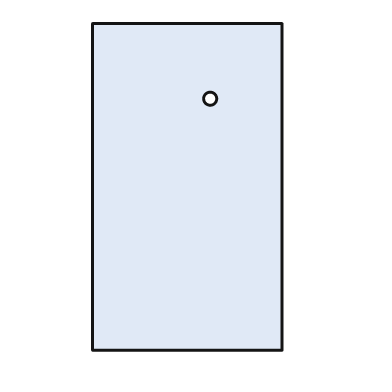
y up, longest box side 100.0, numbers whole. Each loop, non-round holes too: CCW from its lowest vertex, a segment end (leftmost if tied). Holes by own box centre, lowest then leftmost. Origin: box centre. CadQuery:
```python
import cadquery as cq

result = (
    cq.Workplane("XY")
    .moveTo(-29.0, -50.0)
    .lineTo(29.0, -50.0)
    .lineTo(29.0, 50.0)
    .lineTo(-29.0, 50.0)
    .close()
    .moveTo(7.0, 27.0)
    .circle(2.0)
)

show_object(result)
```